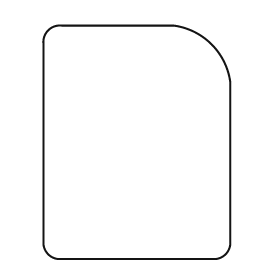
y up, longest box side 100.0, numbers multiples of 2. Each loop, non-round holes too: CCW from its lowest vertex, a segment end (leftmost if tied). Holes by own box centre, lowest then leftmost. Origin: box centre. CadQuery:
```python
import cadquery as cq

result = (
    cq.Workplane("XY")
    .moveTo(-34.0, -50.0)
    .lineTo(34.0, -50.0)
    .threePointArc((38.0, -48.0), (40.0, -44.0))
    .lineTo(40.0, 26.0)
    .threePointArc((32.0, 42.0), (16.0, 50.0))
    .lineTo(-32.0, 50.0)
    .threePointArc((-38.0, 48.0), (-40.0, 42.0))
    .lineTo(-40.0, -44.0)
    .threePointArc((-38.0, -48.0), (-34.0, -50.0))
    .close()
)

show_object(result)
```